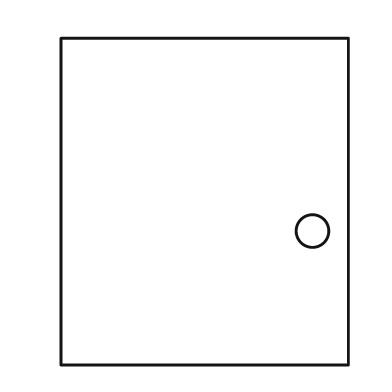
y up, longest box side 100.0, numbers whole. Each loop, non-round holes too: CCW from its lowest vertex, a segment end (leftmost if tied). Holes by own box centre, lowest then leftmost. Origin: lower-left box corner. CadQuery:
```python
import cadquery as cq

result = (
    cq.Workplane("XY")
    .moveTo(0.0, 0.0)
    .lineTo(88.0, 0.0)
    .lineTo(88.0, 100.0)
    .lineTo(0.0, 100.0)
    .close()
    .moveTo(77.0, 41.0)
    .circle(5.0)
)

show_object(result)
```